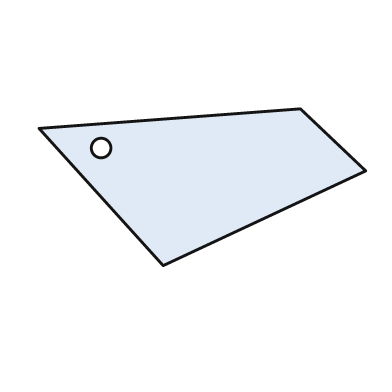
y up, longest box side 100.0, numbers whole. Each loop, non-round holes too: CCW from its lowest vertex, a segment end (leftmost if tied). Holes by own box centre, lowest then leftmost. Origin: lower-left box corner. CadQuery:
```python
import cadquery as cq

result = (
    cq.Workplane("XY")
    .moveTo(38.0, 0.0)
    .lineTo(100.0, 29.0)
    .lineTo(80.0, 48.0)
    .lineTo(0.0, 42.0)
    .close()
    .moveTo(19.0, 36.0)
    .circle(3.0)
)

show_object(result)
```